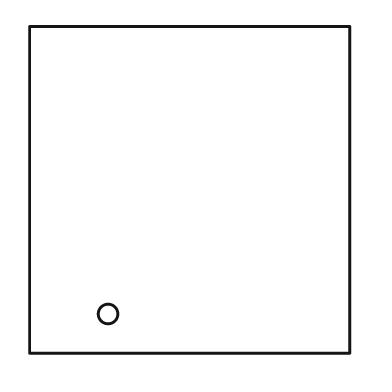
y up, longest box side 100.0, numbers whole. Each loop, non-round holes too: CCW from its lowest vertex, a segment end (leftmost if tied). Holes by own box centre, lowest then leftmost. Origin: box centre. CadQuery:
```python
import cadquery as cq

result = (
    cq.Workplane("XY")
    .moveTo(-49.0, -50.0)
    .lineTo(49.0, -50.0)
    .lineTo(49.0, 50.0)
    .lineTo(-49.0, 50.0)
    .close()
    .moveTo(-25.0, -38.0)
    .circle(3.0)
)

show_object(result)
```